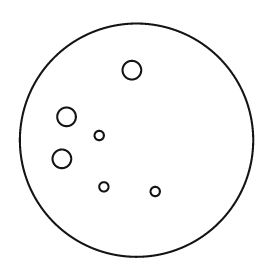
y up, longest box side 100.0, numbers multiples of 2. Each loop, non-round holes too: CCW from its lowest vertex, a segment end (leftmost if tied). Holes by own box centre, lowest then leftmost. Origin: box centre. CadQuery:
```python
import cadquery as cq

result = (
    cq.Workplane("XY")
    .moveTo(0.0, 0.0)
    .circle(50.0)
    .moveTo(8.0, -22.0)
    .circle(2.0)
    .moveTo(-14.0, -20.0)
    .circle(2.0)
    .moveTo(-32.0, -8.0)
    .circle(4.0)
    .moveTo(-16.0, 2.0)
    .circle(2.0)
    .moveTo(-30.0, 10.0)
    .circle(4.0)
    .moveTo(-2.0, 30.0)
    .circle(4.0)
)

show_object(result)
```